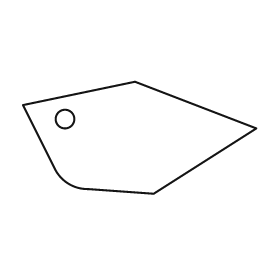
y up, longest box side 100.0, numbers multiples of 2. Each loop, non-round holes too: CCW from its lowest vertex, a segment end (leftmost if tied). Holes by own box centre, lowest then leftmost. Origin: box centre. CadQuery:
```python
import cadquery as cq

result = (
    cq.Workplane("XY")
    .moveTo(6.0, -24.0)
    .lineTo(50.0, 4.0)
    .lineTo(-2.0, 24.0)
    .lineTo(-50.0, 14.0)
    .lineTo(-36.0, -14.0)
    .threePointArc((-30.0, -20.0), (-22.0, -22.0))
    .close()
    .moveTo(-32.0, 8.0)
    .circle(4.0)
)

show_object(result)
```